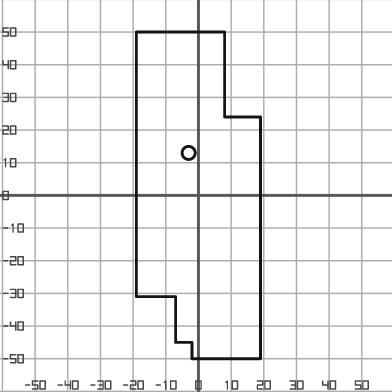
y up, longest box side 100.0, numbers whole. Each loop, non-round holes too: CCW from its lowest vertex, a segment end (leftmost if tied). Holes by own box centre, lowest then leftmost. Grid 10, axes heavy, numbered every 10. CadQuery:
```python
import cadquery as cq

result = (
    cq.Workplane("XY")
    .moveTo(-2.0, -50.0)
    .lineTo(19.0, -50.0)
    .lineTo(19.0, 24.0)
    .lineTo(8.0, 24.0)
    .lineTo(8.0, 50.0)
    .lineTo(-19.0, 50.0)
    .lineTo(-19.0, -31.0)
    .lineTo(-7.0, -31.0)
    .lineTo(-7.0, -45.0)
    .lineTo(-2.0, -45.0)
    .close()
    .moveTo(-3.0, 13.0)
    .circle(2.0)
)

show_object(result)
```